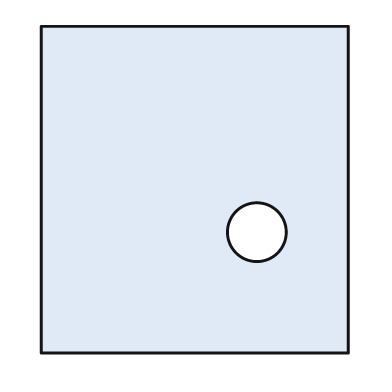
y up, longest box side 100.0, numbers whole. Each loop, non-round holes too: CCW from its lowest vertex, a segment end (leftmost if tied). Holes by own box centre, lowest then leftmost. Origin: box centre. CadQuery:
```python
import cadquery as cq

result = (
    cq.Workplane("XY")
    .moveTo(-47.0, -50.0)
    .lineTo(47.0, -50.0)
    .lineTo(47.0, 50.0)
    .lineTo(-47.0, 50.0)
    .close()
    .moveTo(19.0, -13.0)
    .circle(9.0)
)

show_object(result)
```